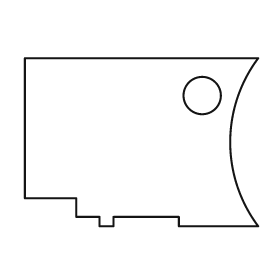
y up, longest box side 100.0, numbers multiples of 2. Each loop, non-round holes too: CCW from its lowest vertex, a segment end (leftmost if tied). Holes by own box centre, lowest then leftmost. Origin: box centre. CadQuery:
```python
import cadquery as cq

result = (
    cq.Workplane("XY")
    .moveTo(-18.0, -36.0)
    .lineTo(-12.0, -36.0)
    .lineTo(-12.0, -32.0)
    .lineTo(16.0, -32.0)
    .lineTo(16.0, -36.0)
    .lineTo(50.0, -36.0)
    .threePointArc((38.0, 0.0), (50.0, 36.0))
    .lineTo(-50.0, 36.0)
    .lineTo(-50.0, -24.0)
    .lineTo(-28.0, -24.0)
    .lineTo(-28.0, -32.0)
    .lineTo(-18.0, -32.0)
    .close()
    .moveTo(26.0, 20.0)
    .circle(8.0)
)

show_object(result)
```